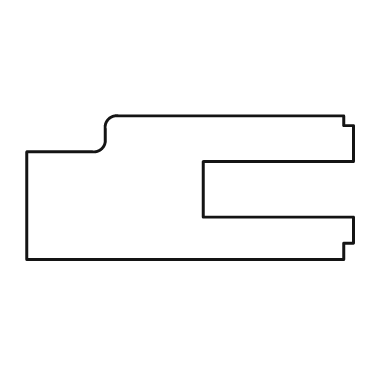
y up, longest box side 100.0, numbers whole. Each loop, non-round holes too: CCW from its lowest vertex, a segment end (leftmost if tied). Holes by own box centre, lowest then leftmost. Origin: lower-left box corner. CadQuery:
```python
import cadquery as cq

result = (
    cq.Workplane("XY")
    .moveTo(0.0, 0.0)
    .lineTo(97.0, 0.0)
    .lineTo(97.0, 5.0)
    .lineTo(100.0, 5.0)
    .lineTo(100.0, 13.0)
    .lineTo(54.0, 13.0)
    .lineTo(54.0, 30.0)
    .lineTo(100.0, 30.0)
    .lineTo(100.0, 41.0)
    .lineTo(97.0, 41.0)
    .lineTo(97.0, 44.0)
    .lineTo(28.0, 44.0)
    .threePointArc((25.0, 43.0), (24.0, 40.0))
    .lineTo(24.0, 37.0)
    .threePointArc((23.0, 34.0), (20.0, 33.0))
    .lineTo(0.0, 33.0)
    .close()
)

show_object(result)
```